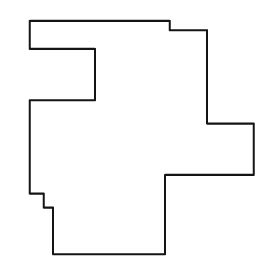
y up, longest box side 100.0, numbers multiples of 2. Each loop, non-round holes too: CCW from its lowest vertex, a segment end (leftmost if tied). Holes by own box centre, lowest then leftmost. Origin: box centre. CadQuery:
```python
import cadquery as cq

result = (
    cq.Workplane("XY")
    .moveTo(-38.0, -50.0)
    .lineTo(10.0, -50.0)
    .lineTo(10.0, -16.0)
    .lineTo(48.0, -16.0)
    .lineTo(48.0, 6.0)
    .lineTo(28.0, 6.0)
    .lineTo(28.0, 46.0)
    .lineTo(12.0, 46.0)
    .lineTo(12.0, 50.0)
    .lineTo(-48.0, 50.0)
    .lineTo(-48.0, 38.0)
    .lineTo(-20.0, 38.0)
    .lineTo(-20.0, 16.0)
    .lineTo(-48.0, 16.0)
    .lineTo(-48.0, -24.0)
    .lineTo(-42.0, -24.0)
    .lineTo(-42.0, -30.0)
    .lineTo(-38.0, -30.0)
    .close()
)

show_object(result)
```